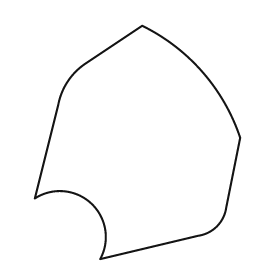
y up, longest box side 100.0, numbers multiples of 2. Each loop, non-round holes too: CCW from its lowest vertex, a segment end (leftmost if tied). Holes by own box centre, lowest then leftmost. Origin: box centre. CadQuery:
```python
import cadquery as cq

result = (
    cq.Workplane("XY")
    .moveTo(-16.0, -50.0)
    .lineTo(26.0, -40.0)
    .threePointArc((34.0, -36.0), (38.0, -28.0))
    .lineTo(44.0, 2.0)
    .threePointArc((28.0, 30.0), (2.0, 50.0))
    .lineTo(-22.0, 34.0)
    .threePointArc((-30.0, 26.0), (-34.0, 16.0))
    .lineTo(-44.0, -24.0)
    .threePointArc((-20.0, -26.0), (-16.0, -50.0))
    .close()
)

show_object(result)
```